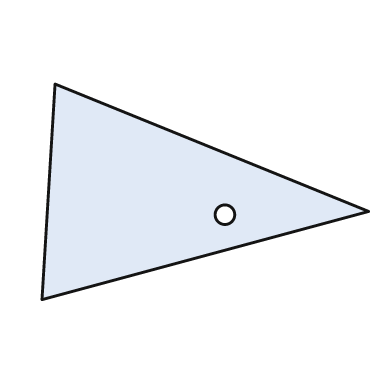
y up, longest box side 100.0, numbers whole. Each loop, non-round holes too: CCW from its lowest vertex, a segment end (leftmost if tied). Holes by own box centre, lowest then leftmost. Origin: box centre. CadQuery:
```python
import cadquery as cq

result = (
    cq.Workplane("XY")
    .moveTo(-50.0, -33.0)
    .lineTo(50.0, -6.0)
    .lineTo(-46.0, 33.0)
    .close()
    .moveTo(6.0, -7.0)
    .circle(3.0)
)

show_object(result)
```